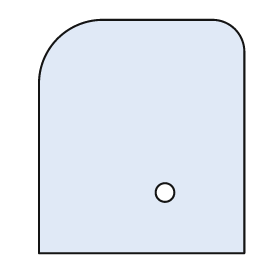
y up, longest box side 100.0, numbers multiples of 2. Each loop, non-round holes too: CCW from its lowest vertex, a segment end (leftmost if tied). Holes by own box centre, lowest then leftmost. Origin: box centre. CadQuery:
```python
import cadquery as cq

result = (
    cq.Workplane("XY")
    .moveTo(-44.0, -50.0)
    .lineTo(44.0, -50.0)
    .lineTo(44.0, 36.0)
    .threePointArc((40.0, 46.0), (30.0, 50.0))
    .lineTo(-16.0, 50.0)
    .threePointArc((-36.0, 42.0), (-44.0, 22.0))
    .close()
    .moveTo(10.0, -24.0)
    .circle(4.0)
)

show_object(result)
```